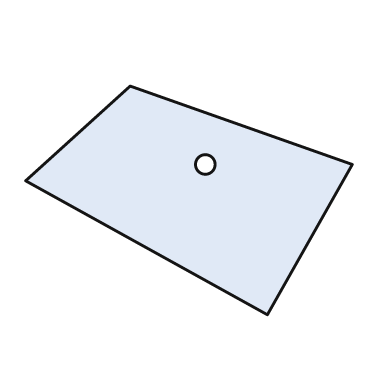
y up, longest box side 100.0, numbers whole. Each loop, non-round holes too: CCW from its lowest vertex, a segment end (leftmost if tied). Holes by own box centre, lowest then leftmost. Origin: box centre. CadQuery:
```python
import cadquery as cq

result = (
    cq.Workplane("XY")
    .moveTo(24.0, -35.0)
    .lineTo(50.0, 11.0)
    .lineTo(-18.0, 35.0)
    .lineTo(-50.0, 6.0)
    .close()
    .moveTo(5.0, 11.0)
    .circle(3.0)
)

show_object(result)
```